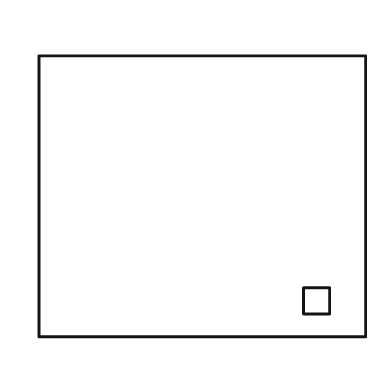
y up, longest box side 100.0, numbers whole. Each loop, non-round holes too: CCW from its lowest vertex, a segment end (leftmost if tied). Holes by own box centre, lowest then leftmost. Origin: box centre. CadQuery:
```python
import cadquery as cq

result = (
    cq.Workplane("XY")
    .moveTo(-50.0, -43.0)
    .lineTo(50.0, -43.0)
    .lineTo(50.0, 43.0)
    .lineTo(-50.0, 43.0)
    .close()
    .moveTo(31.0, -36.0)
    .lineTo(39.0, -36.0)
    .lineTo(39.0, -28.0)
    .lineTo(31.0, -28.0)
    .close()
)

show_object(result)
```